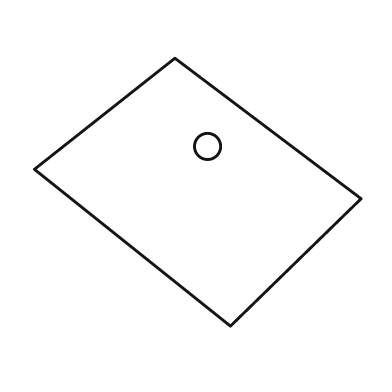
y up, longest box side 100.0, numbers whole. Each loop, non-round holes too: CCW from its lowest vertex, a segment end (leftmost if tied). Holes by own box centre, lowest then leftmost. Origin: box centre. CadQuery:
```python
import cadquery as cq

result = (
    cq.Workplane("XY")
    .moveTo(10.0, -41.0)
    .lineTo(50.0, -2.0)
    .lineTo(-7.0, 41.0)
    .lineTo(-50.0, 7.0)
    .close()
    .moveTo(3.0, 14.0)
    .circle(4.0)
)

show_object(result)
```